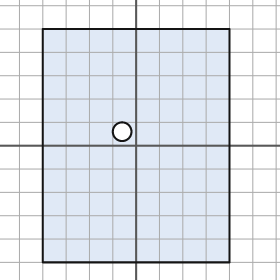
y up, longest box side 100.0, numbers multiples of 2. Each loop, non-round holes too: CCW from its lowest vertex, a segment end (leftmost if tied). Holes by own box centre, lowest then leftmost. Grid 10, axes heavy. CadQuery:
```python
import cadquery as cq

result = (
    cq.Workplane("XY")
    .moveTo(-40.0, -50.0)
    .lineTo(40.0, -50.0)
    .lineTo(40.0, 50.0)
    .lineTo(-40.0, 50.0)
    .close()
    .moveTo(-6.0, 6.0)
    .circle(4.0)
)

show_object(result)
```